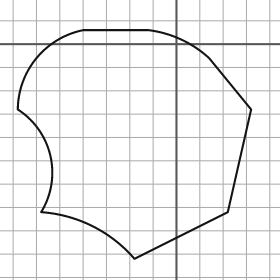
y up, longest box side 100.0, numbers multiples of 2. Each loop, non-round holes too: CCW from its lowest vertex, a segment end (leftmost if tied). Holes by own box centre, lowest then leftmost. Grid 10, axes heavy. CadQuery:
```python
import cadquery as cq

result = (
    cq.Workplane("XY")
    .moveTo(-18.0, -92.0)
    .lineTo(22.0, -72.0)
    .lineTo(32.0, -28.0)
    .lineTo(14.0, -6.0)
    .threePointArc((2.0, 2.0), (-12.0, 6.0))
    .lineTo(-40.0, 6.0)
    .threePointArc((-60.0, -6.0), (-68.0, -28.0))
    .threePointArc((-54.0, -48.0), (-58.0, -72.0))
    .threePointArc((-36.0, -78.0), (-18.0, -92.0))
    .close()
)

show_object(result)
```